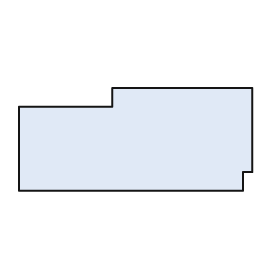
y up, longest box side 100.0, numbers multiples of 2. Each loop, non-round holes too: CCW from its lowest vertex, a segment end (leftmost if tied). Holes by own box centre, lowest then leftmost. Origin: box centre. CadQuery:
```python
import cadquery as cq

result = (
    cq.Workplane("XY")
    .moveTo(-50.0, -22.0)
    .lineTo(46.0, -22.0)
    .lineTo(46.0, -14.0)
    .lineTo(50.0, -14.0)
    .lineTo(50.0, 22.0)
    .lineTo(-10.0, 22.0)
    .lineTo(-10.0, 14.0)
    .lineTo(-50.0, 14.0)
    .close()
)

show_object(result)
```